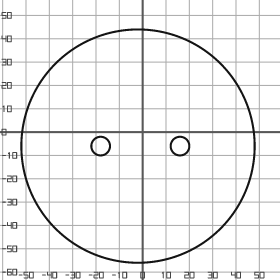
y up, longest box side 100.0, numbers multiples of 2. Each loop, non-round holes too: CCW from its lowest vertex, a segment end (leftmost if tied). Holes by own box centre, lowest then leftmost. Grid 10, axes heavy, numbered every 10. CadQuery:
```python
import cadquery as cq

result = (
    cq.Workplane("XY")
    .moveTo(-2.0, -6.0)
    .circle(50.0)
    .moveTo(-18.0, -6.0)
    .circle(4.0)
    .moveTo(16.0, -6.0)
    .circle(4.0)
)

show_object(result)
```